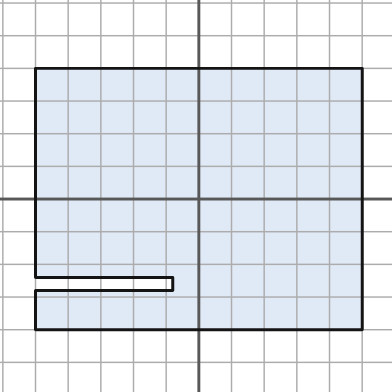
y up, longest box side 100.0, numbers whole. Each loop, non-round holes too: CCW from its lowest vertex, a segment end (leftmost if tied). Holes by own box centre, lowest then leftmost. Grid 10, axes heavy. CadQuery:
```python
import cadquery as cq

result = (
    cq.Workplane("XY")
    .moveTo(-50.0, -40.0)
    .lineTo(50.0, -40.0)
    .lineTo(50.0, 40.0)
    .lineTo(-50.0, 40.0)
    .lineTo(-50.0, -24.0)
    .lineTo(-8.0, -24.0)
    .lineTo(-8.0, -28.0)
    .lineTo(-50.0, -28.0)
    .close()
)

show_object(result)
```